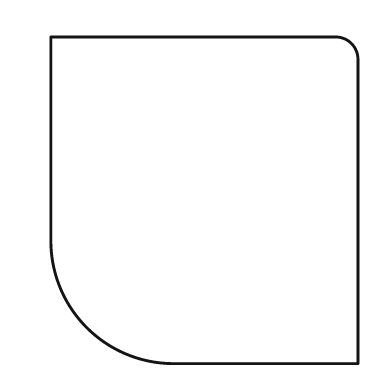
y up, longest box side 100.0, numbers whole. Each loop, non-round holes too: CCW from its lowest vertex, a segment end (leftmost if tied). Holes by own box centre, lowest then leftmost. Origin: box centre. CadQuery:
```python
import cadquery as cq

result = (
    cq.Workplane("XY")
    .moveTo(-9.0, -50.0)
    .lineTo(47.0, -50.0)
    .lineTo(47.0, 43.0)
    .threePointArc((45.0, 48.0), (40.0, 50.0))
    .lineTo(-47.0, 50.0)
    .lineTo(-47.0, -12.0)
    .threePointArc((-36.0, -39.0), (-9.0, -50.0))
    .close()
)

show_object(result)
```